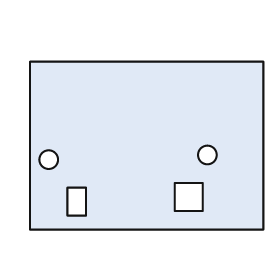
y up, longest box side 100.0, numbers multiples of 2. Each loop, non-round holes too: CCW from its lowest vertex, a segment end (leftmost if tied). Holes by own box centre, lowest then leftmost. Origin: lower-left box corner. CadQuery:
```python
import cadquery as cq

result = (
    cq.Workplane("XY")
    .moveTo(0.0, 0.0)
    .lineTo(100.0, 0.0)
    .lineTo(100.0, 72.0)
    .lineTo(0.0, 72.0)
    .close()
    .moveTo(16.0, 6.0)
    .lineTo(24.0, 6.0)
    .lineTo(24.0, 18.0)
    .lineTo(16.0, 18.0)
    .close()
    .moveTo(62.0, 8.0)
    .lineTo(74.0, 8.0)
    .lineTo(74.0, 20.0)
    .lineTo(62.0, 20.0)
    .close()
    .moveTo(8.0, 30.0)
    .circle(4.0)
    .moveTo(76.0, 32.0)
    .circle(4.0)
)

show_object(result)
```